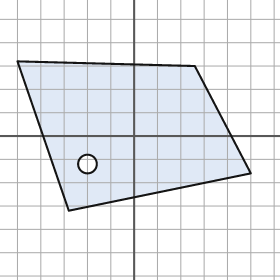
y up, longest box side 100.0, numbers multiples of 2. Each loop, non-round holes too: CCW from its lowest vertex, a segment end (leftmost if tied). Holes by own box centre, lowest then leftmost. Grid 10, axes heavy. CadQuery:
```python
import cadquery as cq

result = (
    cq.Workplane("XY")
    .moveTo(-28.0, -32.0)
    .lineTo(50.0, -16.0)
    .lineTo(26.0, 30.0)
    .lineTo(-50.0, 32.0)
    .close()
    .moveTo(-20.0, -12.0)
    .circle(4.0)
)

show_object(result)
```